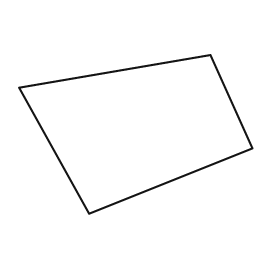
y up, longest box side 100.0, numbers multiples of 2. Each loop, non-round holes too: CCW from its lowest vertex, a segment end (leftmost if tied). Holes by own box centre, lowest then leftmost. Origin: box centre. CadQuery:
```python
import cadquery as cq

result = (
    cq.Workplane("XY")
    .moveTo(-20.0, -34.0)
    .lineTo(50.0, -6.0)
    .lineTo(32.0, 34.0)
    .lineTo(-50.0, 20.0)
    .close()
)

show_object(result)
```